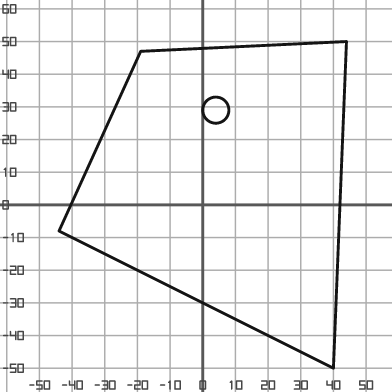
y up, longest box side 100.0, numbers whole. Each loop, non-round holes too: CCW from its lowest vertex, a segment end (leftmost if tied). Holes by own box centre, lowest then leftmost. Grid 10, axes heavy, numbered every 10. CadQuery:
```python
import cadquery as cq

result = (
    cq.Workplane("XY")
    .moveTo(40.0, -50.0)
    .lineTo(44.0, 50.0)
    .lineTo(-19.0, 47.0)
    .lineTo(-44.0, -8.0)
    .close()
    .moveTo(4.0, 29.0)
    .circle(4.0)
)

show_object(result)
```